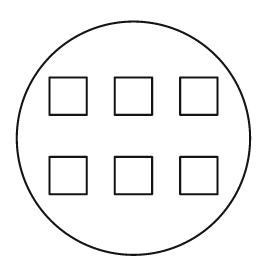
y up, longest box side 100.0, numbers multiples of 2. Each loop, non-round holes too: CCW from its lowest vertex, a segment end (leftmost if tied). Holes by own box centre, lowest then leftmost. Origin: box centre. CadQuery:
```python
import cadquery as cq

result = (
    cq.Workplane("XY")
    .moveTo(0.0, 0.0)
    .circle(50.0)
    .moveTo(-36.0, -24.0)
    .lineTo(-20.0, -24.0)
    .lineTo(-20.0, -8.0)
    .lineTo(-36.0, -8.0)
    .close()
    .moveTo(-8.0, -24.0)
    .lineTo(8.0, -24.0)
    .lineTo(8.0, -8.0)
    .lineTo(-8.0, -8.0)
    .close()
    .moveTo(20.0, -24.0)
    .lineTo(36.0, -24.0)
    .lineTo(36.0, -8.0)
    .lineTo(20.0, -8.0)
    .close()
    .moveTo(-36.0, 10.0)
    .lineTo(-20.0, 10.0)
    .lineTo(-20.0, 26.0)
    .lineTo(-36.0, 26.0)
    .close()
    .moveTo(-8.0, 10.0)
    .lineTo(8.0, 10.0)
    .lineTo(8.0, 26.0)
    .lineTo(-8.0, 26.0)
    .close()
    .moveTo(20.0, 10.0)
    .lineTo(36.0, 10.0)
    .lineTo(36.0, 26.0)
    .lineTo(20.0, 26.0)
    .close()
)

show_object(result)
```